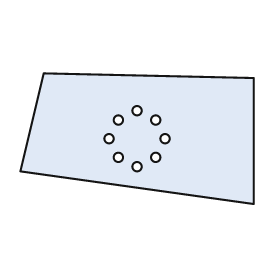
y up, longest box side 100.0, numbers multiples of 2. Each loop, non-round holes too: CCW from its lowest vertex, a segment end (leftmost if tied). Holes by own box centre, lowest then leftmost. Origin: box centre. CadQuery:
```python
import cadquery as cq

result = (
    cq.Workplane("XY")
    .moveTo(50.0, -28.0)
    .lineTo(50.0, 26.0)
    .lineTo(-40.0, 28.0)
    .lineTo(-50.0, -14.0)
    .close()
    .moveTo(0.0, -12.0)
    .circle(2.0)
    .moveTo(-8.0, -8.0)
    .circle(2.0)
    .moveTo(8.0, -8.0)
    .circle(2.0)
    .moveTo(-12.0, 0.0)
    .circle(2.0)
    .moveTo(12.0, 0.0)
    .circle(2.0)
    .moveTo(-8.0, 8.0)
    .circle(2.0)
    .moveTo(8.0, 8.0)
    .circle(2.0)
    .moveTo(0.0, 12.0)
    .circle(2.0)
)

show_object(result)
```